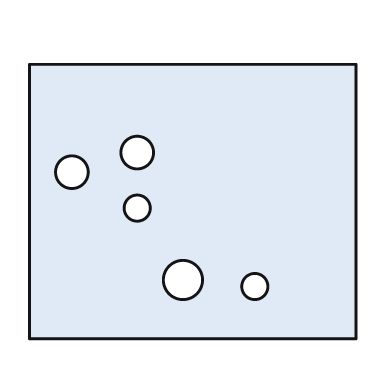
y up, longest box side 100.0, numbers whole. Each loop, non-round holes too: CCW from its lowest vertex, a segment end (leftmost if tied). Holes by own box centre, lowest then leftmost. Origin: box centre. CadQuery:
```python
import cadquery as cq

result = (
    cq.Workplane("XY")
    .moveTo(-50.0, -42.0)
    .lineTo(50.0, -42.0)
    .lineTo(50.0, 42.0)
    .lineTo(-50.0, 42.0)
    .close()
    .moveTo(19.0, -26.0)
    .circle(4.0)
    .moveTo(-3.0, -24.0)
    .circle(6.0)
    .moveTo(-17.0, -2.0)
    .circle(4.0)
    .moveTo(-37.0, 9.0)
    .circle(5.0)
    .moveTo(-17.0, 15.0)
    .circle(5.0)
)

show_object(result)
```